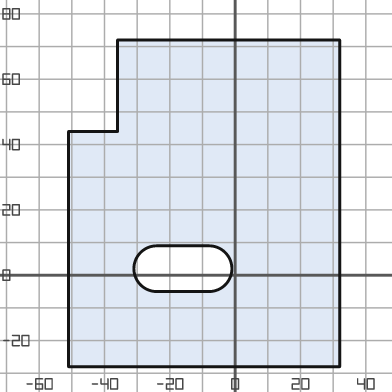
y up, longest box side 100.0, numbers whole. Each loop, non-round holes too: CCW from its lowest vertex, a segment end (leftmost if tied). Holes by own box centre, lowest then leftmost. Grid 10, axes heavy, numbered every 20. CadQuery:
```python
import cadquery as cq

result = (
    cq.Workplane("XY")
    .moveTo(-51.0, -28.0)
    .lineTo(32.0, -28.0)
    .lineTo(32.0, 72.0)
    .lineTo(-36.0, 72.0)
    .lineTo(-36.0, 44.0)
    .lineTo(-51.0, 44.0)
    .close()
    .moveTo(-24.0, -5.0)
    .lineTo(-8.0, -5.0)
    .threePointArc((-1.0, 2.0), (-8.0, 9.0))
    .lineTo(-24.0, 9.0)
    .threePointArc((-31.0, 2.0), (-24.0, -5.0))
    .close()
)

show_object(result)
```